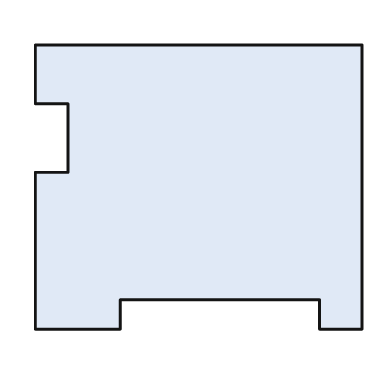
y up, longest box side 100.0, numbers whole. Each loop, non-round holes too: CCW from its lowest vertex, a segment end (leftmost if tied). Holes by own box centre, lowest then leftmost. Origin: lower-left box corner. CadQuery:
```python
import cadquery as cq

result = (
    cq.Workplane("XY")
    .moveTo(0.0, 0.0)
    .lineTo(26.0, 0.0)
    .lineTo(26.0, 9.0)
    .lineTo(87.0, 9.0)
    .lineTo(87.0, 0.0)
    .lineTo(100.0, 0.0)
    .lineTo(100.0, 87.0)
    .lineTo(0.0, 87.0)
    .lineTo(0.0, 69.0)
    .lineTo(10.0, 69.0)
    .lineTo(10.0, 48.0)
    .lineTo(0.0, 48.0)
    .close()
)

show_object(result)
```